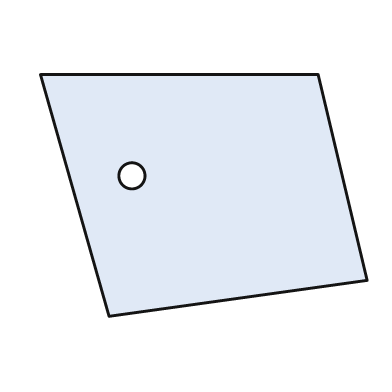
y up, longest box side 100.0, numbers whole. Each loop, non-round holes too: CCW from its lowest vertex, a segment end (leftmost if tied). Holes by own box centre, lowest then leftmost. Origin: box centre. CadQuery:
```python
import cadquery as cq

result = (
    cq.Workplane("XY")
    .moveTo(-29.0, -37.0)
    .lineTo(50.0, -26.0)
    .lineTo(35.0, 37.0)
    .lineTo(-50.0, 37.0)
    .close()
    .moveTo(-22.0, 6.0)
    .circle(4.0)
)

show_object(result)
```